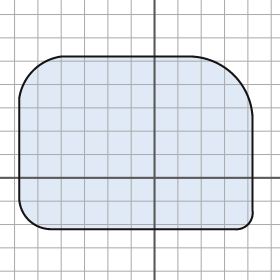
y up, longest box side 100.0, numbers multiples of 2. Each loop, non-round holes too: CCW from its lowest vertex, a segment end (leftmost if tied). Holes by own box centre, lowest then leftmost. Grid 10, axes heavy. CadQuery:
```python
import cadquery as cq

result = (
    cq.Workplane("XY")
    .moveTo(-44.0, -22.0)
    .lineTo(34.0, -22.0)
    .threePointArc((40.0, -20.0), (42.0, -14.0))
    .lineTo(42.0, 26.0)
    .threePointArc((34.0, 44.0), (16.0, 52.0))
    .lineTo(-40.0, 52.0)
    .threePointArc((-52.0, 46.0), (-58.0, 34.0))
    .lineTo(-58.0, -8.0)
    .threePointArc((-54.0, -18.0), (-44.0, -22.0))
    .close()
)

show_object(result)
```